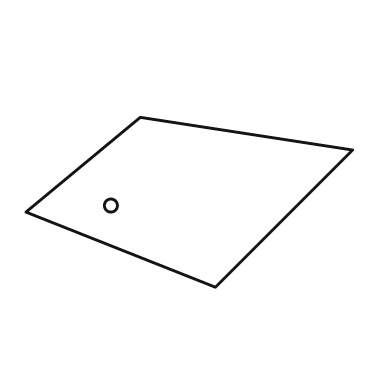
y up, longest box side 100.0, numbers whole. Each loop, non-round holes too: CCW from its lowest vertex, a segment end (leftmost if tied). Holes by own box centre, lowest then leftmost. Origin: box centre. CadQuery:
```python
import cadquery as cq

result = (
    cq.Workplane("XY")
    .moveTo(8.0, -26.0)
    .lineTo(50.0, 16.0)
    .lineTo(-15.0, 26.0)
    .lineTo(-50.0, -3.0)
    .close()
    .moveTo(-24.0, -1.0)
    .circle(2.0)
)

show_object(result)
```